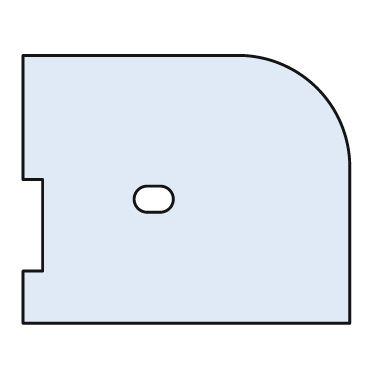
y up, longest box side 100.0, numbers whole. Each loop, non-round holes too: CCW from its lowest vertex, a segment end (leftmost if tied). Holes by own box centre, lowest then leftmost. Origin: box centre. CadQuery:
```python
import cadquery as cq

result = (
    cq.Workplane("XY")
    .moveTo(-50.0, -41.0)
    .lineTo(50.0, -41.0)
    .lineTo(50.0, 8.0)
    .threePointArc((40.0, 31.0), (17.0, 41.0))
    .lineTo(-50.0, 41.0)
    .lineTo(-50.0, 3.0)
    .lineTo(-44.0, 3.0)
    .lineTo(-44.0, -25.0)
    .lineTo(-50.0, -25.0)
    .close()
    .moveTo(-12.0, -7.0)
    .lineTo(-8.0, -7.0)
    .threePointArc((-4.0, -3.0), (-8.0, 1.0))
    .lineTo(-12.0, 1.0)
    .threePointArc((-16.0, -3.0), (-12.0, -7.0))
    .close()
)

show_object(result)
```